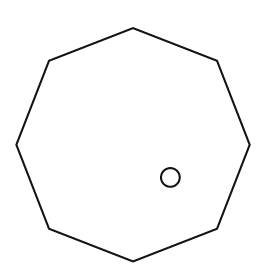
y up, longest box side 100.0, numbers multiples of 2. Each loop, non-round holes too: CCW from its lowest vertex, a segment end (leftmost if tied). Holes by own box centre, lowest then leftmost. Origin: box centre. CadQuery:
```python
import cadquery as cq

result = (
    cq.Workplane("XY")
    .moveTo(0.0, -50.0)
    .lineTo(36.0, -36.0)
    .lineTo(50.0, 0.0)
    .lineTo(36.0, 36.0)
    .lineTo(0.0, 50.0)
    .lineTo(-36.0, 36.0)
    .lineTo(-50.0, 0.0)
    .lineTo(-36.0, -36.0)
    .close()
    .moveTo(16.0, -14.0)
    .circle(4.0)
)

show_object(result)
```